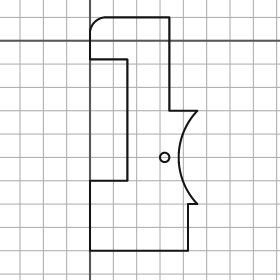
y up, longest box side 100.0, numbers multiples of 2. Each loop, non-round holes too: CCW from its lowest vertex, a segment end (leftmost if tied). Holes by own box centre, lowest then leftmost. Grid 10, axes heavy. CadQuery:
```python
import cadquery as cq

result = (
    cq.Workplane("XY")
    .moveTo(0.0, -90.0)
    .lineTo(42.0, -90.0)
    .lineTo(42.0, -70.0)
    .lineTo(46.0, -70.0)
    .threePointArc((38.0, -50.0), (46.0, -30.0))
    .lineTo(34.0, -30.0)
    .lineTo(34.0, 10.0)
    .lineTo(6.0, 10.0)
    .threePointArc((2.0, 8.0), (0.0, 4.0))
    .lineTo(0.0, -8.0)
    .lineTo(16.0, -8.0)
    .lineTo(16.0, -60.0)
    .lineTo(0.0, -60.0)
    .close()
    .moveTo(32.0, -50.0)
    .circle(2.0)
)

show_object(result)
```